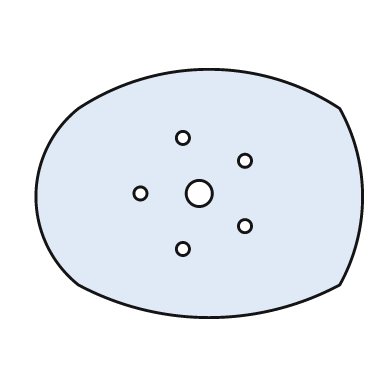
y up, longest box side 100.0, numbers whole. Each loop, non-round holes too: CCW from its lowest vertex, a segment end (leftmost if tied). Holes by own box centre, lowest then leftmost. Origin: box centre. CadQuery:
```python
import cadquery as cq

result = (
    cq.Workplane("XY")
    .moveTo(-37.0, -28.0)
    .threePointArc((3.0, -38.0), (43.0, -28.0))
    .threePointArc((50.0, -1.0), (43.0, 26.0))
    .threePointArc((3.0, 38.0), (-37.0, 26.0))
    .threePointArc((-50.0, -1.0), (-37.0, -28.0))
    .close()
    .moveTo(-5.0, -17.0)
    .circle(2.0)
    .moveTo(14.0, -10.0)
    .circle(2.0)
    .moveTo(-18.0, 0.0)
    .circle(2.0)
    .moveTo(0.0, 0.0)
    .circle(4.0)
    .moveTo(14.0, 10.0)
    .circle(2.0)
    .moveTo(-5.0, 17.0)
    .circle(2.0)
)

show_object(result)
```